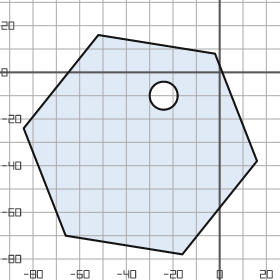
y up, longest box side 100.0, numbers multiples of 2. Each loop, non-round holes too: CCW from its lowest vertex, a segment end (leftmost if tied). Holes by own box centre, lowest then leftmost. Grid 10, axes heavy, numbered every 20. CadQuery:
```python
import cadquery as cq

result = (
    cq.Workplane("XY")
    .moveTo(-16.0, -78.0)
    .lineTo(16.0, -38.0)
    .lineTo(-2.0, 8.0)
    .lineTo(-52.0, 16.0)
    .lineTo(-84.0, -24.0)
    .lineTo(-66.0, -70.0)
    .close()
    .moveTo(-24.0, -10.0)
    .circle(6.0)
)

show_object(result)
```